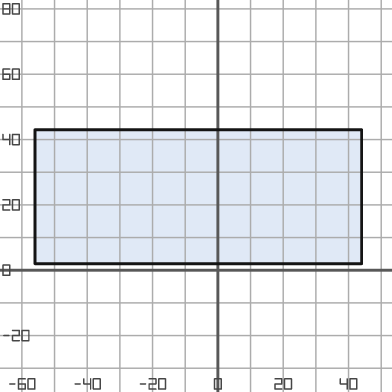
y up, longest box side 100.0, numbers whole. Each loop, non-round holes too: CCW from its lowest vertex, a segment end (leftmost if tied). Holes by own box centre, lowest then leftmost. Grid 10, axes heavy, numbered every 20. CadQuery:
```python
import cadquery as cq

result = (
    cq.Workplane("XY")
    .moveTo(-56.0, 2.0)
    .lineTo(44.0, 2.0)
    .lineTo(44.0, 43.0)
    .lineTo(-56.0, 43.0)
    .close()
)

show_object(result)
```